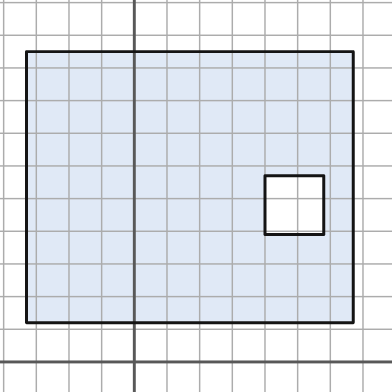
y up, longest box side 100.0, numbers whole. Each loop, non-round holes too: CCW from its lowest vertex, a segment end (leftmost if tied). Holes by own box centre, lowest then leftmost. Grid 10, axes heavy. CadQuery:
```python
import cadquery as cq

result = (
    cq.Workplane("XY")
    .moveTo(-33.0, 12.0)
    .lineTo(67.0, 12.0)
    .lineTo(67.0, 95.0)
    .lineTo(-33.0, 95.0)
    .close()
    .moveTo(40.0, 39.0)
    .lineTo(58.0, 39.0)
    .lineTo(58.0, 57.0)
    .lineTo(40.0, 57.0)
    .close()
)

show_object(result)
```